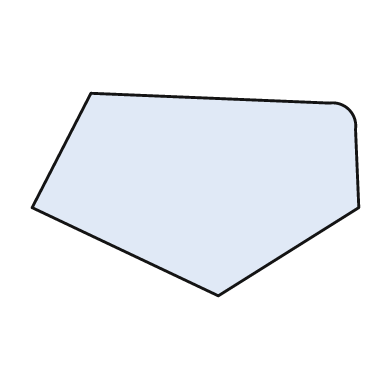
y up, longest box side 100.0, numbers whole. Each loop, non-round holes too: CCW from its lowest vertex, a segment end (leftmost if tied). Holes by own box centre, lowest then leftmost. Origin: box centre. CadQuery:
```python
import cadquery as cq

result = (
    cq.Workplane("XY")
    .moveTo(7.0, -31.0)
    .lineTo(50.0, -4.0)
    .lineTo(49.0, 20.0)
    .threePointArc((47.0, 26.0), (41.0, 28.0))
    .lineTo(-32.0, 31.0)
    .lineTo(-50.0, -4.0)
    .close()
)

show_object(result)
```